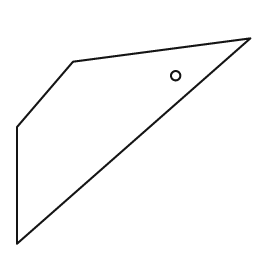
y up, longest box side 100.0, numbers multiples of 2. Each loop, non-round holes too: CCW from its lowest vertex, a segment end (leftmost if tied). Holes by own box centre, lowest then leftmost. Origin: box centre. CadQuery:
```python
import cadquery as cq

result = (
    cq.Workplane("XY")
    .moveTo(-50.0, -44.0)
    .lineTo(50.0, 44.0)
    .lineTo(-26.0, 34.0)
    .lineTo(-50.0, 6.0)
    .close()
    .moveTo(18.0, 28.0)
    .circle(2.0)
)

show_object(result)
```